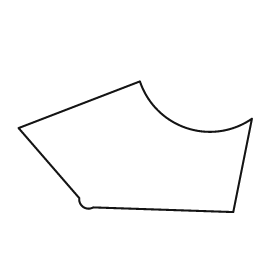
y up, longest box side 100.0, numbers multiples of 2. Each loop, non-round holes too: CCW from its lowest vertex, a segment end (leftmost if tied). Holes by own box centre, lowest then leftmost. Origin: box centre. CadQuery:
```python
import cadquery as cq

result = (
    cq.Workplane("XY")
    .moveTo(42.0, -28.0)
    .lineTo(50.0, 12.0)
    .threePointArc((22.0, 8.0), (2.0, 28.0))
    .lineTo(-50.0, 8.0)
    .lineTo(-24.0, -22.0)
    .threePointArc((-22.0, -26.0), (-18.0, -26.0))
    .close()
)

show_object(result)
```